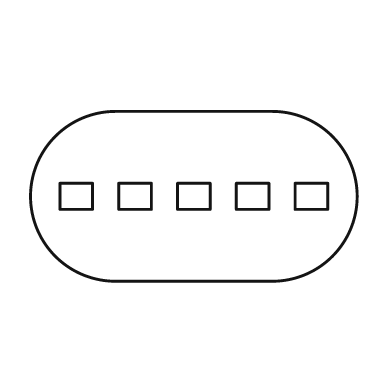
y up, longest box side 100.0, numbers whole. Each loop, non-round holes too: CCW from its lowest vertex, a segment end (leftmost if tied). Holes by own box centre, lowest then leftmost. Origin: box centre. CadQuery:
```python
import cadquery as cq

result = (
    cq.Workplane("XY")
    .moveTo(-24.0, -26.0)
    .lineTo(24.0, -26.0)
    .threePointArc((50.0, 0.0), (24.0, 26.0))
    .lineTo(-24.0, 26.0)
    .threePointArc((-50.0, 0.0), (-24.0, -26.0))
    .close()
    .moveTo(-41.0, -4.0)
    .lineTo(-31.0, -4.0)
    .lineTo(-31.0, 4.0)
    .lineTo(-41.0, 4.0)
    .close()
    .moveTo(-23.0, -4.0)
    .lineTo(-13.0, -4.0)
    .lineTo(-13.0, 4.0)
    .lineTo(-23.0, 4.0)
    .close()
    .moveTo(-5.0, -4.0)
    .lineTo(5.0, -4.0)
    .lineTo(5.0, 4.0)
    .lineTo(-5.0, 4.0)
    .close()
    .moveTo(13.0, -4.0)
    .lineTo(23.0, -4.0)
    .lineTo(23.0, 4.0)
    .lineTo(13.0, 4.0)
    .close()
    .moveTo(31.0, -4.0)
    .lineTo(41.0, -4.0)
    .lineTo(41.0, 4.0)
    .lineTo(31.0, 4.0)
    .close()
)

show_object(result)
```